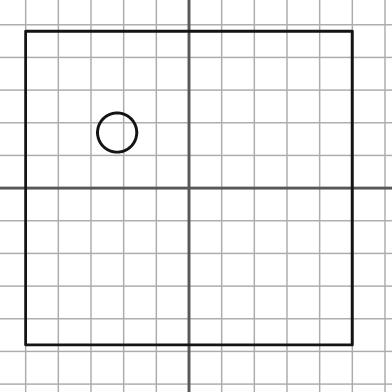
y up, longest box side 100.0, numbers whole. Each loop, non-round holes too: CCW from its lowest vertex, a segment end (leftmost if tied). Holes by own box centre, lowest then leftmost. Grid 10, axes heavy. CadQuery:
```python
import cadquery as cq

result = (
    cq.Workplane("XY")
    .moveTo(-50.0, -48.0)
    .lineTo(50.0, -48.0)
    .lineTo(50.0, 48.0)
    .lineTo(-50.0, 48.0)
    .close()
    .moveTo(-22.0, 17.0)
    .circle(6.0)
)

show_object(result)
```